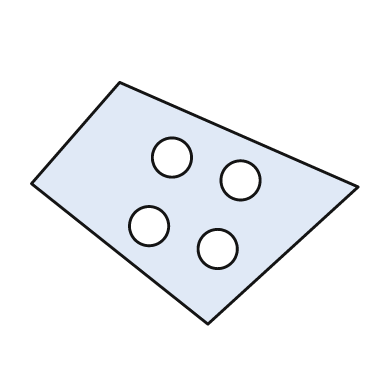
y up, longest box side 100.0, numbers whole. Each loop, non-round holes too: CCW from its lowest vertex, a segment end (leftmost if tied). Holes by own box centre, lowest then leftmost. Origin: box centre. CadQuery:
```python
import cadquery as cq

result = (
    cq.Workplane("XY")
    .moveTo(4.0, -37.0)
    .lineTo(50.0, 5.0)
    .lineTo(-23.0, 37.0)
    .lineTo(-50.0, 6.0)
    .close()
    .moveTo(7.0, -14.0)
    .circle(6.0)
    .moveTo(-14.0, -7.0)
    .circle(6.0)
    .moveTo(14.0, 7.0)
    .circle(6.0)
    .moveTo(-7.0, 14.0)
    .circle(6.0)
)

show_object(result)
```